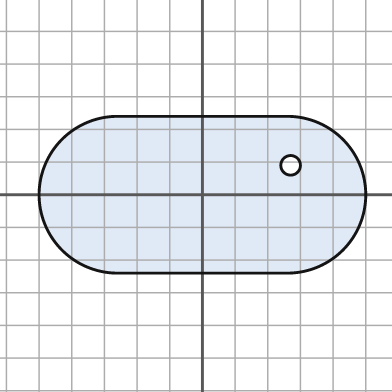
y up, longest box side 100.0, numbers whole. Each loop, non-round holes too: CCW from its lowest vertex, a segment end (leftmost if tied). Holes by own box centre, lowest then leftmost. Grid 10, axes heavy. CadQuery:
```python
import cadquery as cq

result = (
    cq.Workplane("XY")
    .moveTo(-26.0, -24.0)
    .lineTo(26.0, -24.0)
    .threePointArc((50.0, 0.0), (26.0, 24.0))
    .lineTo(-26.0, 24.0)
    .threePointArc((-50.0, 0.0), (-26.0, -24.0))
    .close()
    .moveTo(27.0, 9.0)
    .circle(3.0)
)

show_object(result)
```